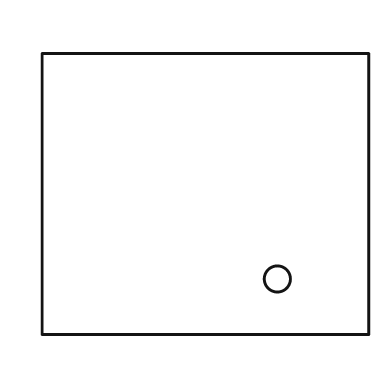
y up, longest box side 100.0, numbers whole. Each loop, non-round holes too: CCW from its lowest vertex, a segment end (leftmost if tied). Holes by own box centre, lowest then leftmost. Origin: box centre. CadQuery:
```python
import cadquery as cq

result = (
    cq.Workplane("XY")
    .moveTo(-50.0, -43.0)
    .lineTo(50.0, -43.0)
    .lineTo(50.0, 43.0)
    .lineTo(-50.0, 43.0)
    .close()
    .moveTo(22.0, -26.0)
    .circle(4.0)
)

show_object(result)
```